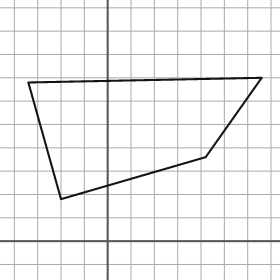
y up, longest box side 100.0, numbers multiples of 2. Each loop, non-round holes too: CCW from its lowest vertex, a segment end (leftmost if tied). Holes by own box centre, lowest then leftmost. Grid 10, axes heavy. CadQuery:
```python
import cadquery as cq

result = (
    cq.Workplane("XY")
    .moveTo(-20.0, 18.0)
    .lineTo(42.0, 36.0)
    .lineTo(66.0, 70.0)
    .lineTo(-34.0, 68.0)
    .close()
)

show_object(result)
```